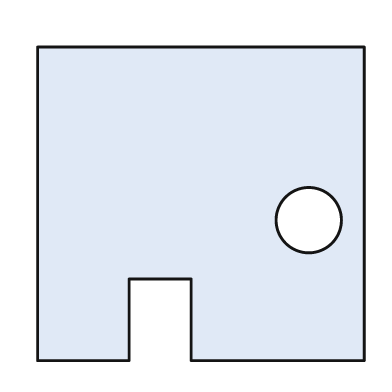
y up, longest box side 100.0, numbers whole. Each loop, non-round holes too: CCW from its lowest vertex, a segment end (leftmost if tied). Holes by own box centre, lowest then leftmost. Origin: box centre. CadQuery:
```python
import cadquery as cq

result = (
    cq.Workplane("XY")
    .moveTo(-50.0, -48.0)
    .lineTo(-22.0, -48.0)
    .lineTo(-22.0, -23.0)
    .lineTo(-3.0, -23.0)
    .lineTo(-3.0, -48.0)
    .lineTo(50.0, -48.0)
    .lineTo(50.0, 48.0)
    .lineTo(-50.0, 48.0)
    .close()
    .moveTo(33.0, -5.0)
    .circle(10.0)
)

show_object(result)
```